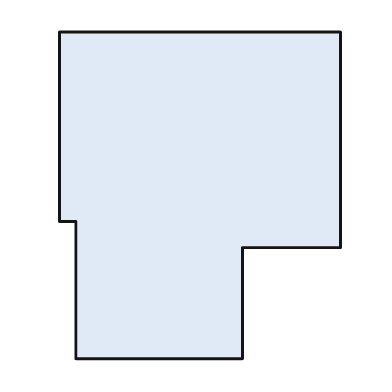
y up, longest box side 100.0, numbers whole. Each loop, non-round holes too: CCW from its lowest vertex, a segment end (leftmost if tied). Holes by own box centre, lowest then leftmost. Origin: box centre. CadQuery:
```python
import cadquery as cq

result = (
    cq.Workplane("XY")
    .moveTo(-38.0, -50.0)
    .lineTo(13.0, -50.0)
    .lineTo(13.0, -16.0)
    .lineTo(43.0, -16.0)
    .lineTo(43.0, 50.0)
    .lineTo(-43.0, 50.0)
    .lineTo(-43.0, -8.0)
    .lineTo(-38.0, -8.0)
    .close()
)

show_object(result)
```